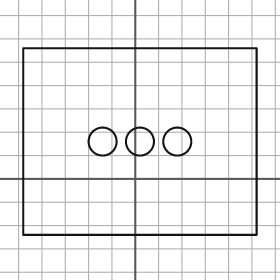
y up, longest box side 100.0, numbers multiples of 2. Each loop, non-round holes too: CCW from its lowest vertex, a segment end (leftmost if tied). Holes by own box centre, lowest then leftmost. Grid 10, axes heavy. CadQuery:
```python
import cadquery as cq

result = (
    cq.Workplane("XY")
    .moveTo(-48.0, -24.0)
    .lineTo(52.0, -24.0)
    .lineTo(52.0, 56.0)
    .lineTo(-48.0, 56.0)
    .close()
    .moveTo(-14.0, 16.0)
    .circle(6.0)
    .moveTo(2.0, 16.0)
    .circle(6.0)
    .moveTo(18.0, 16.0)
    .circle(6.0)
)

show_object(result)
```